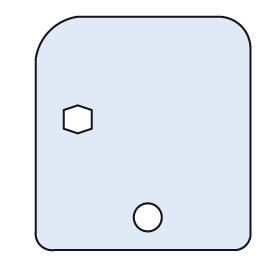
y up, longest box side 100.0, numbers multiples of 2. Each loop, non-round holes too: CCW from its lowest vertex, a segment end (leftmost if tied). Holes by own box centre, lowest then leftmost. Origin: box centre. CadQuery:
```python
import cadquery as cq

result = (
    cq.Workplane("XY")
    .moveTo(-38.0, -50.0)
    .lineTo(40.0, -50.0)
    .threePointArc((44.0, -48.0), (46.0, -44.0))
    .lineTo(46.0, 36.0)
    .threePointArc((42.0, 46.0), (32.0, 50.0))
    .lineTo(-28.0, 50.0)
    .threePointArc((-40.0, 44.0), (-46.0, 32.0))
    .lineTo(-46.0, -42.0)
    .threePointArc((-44.0, -48.0), (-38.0, -50.0))
    .close()
    .moveTo(2.0, -36.0)
    .circle(6.0)
    .moveTo(-28.0, 0.0)
    .lineTo(-22.0, 2.0)
    .lineTo(-22.0, 10.0)
    .lineTo(-28.0, 12.0)
    .lineTo(-34.0, 10.0)
    .lineTo(-34.0, 2.0)
    .close()
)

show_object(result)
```